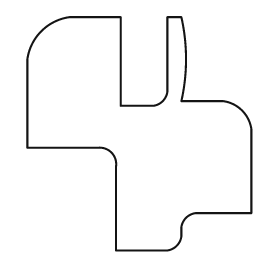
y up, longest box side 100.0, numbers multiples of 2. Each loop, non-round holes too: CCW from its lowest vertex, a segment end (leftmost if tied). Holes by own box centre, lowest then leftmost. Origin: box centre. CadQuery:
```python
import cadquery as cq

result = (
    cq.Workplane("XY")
    .moveTo(-10.0, -50.0)
    .lineTo(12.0, -50.0)
    .threePointArc((16.0, -48.0), (18.0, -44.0))
    .lineTo(18.0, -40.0)
    .threePointArc((20.0, -36.0), (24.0, -34.0))
    .lineTo(48.0, -34.0)
    .lineTo(48.0, 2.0)
    .threePointArc((44.0, 10.0), (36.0, 14.0))
    .lineTo(18.0, 14.0)
    .threePointArc((20.0, 32.0), (18.0, 50.0))
    .lineTo(12.0, 50.0)
    .lineTo(12.0, 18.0)
    .threePointArc((10.0, 14.0), (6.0, 12.0))
    .lineTo(-8.0, 12.0)
    .lineTo(-8.0, 50.0)
    .lineTo(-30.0, 50.0)
    .threePointArc((-42.0, 44.0), (-48.0, 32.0))
    .lineTo(-48.0, -6.0)
    .lineTo(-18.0, -6.0)
    .threePointArc((-12.0, -8.0), (-10.0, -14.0))
    .close()
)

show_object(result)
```